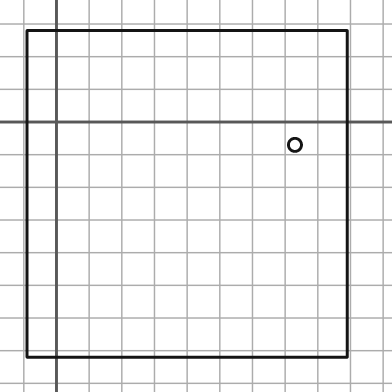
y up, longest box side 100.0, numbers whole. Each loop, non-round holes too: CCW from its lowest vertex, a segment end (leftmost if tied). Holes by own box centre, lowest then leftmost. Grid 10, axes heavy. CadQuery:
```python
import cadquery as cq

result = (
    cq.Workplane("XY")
    .moveTo(-9.0, -72.0)
    .lineTo(89.0, -72.0)
    .lineTo(89.0, 28.0)
    .lineTo(-9.0, 28.0)
    .close()
    .moveTo(73.0, -7.0)
    .circle(2.0)
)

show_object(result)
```